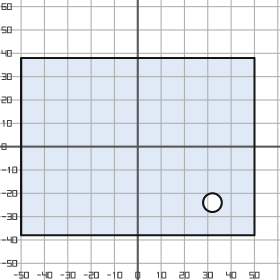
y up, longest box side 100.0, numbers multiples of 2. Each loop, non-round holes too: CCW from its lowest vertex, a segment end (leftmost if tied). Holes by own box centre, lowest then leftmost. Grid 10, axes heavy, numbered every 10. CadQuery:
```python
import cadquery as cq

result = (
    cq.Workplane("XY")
    .moveTo(-50.0, -38.0)
    .lineTo(50.0, -38.0)
    .lineTo(50.0, 38.0)
    .lineTo(-50.0, 38.0)
    .close()
    .moveTo(32.0, -24.0)
    .circle(4.0)
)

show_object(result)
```